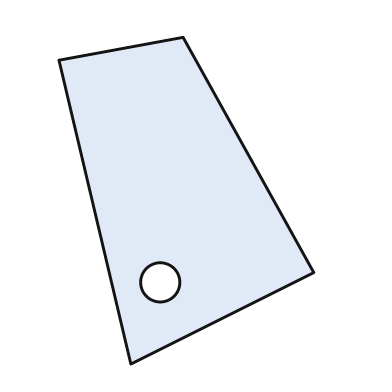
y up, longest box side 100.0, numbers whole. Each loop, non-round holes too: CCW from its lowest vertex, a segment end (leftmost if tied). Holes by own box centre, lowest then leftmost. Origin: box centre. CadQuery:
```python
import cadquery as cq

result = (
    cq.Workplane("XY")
    .moveTo(-17.0, -50.0)
    .lineTo(39.0, -22.0)
    .lineTo(-1.0, 50.0)
    .lineTo(-39.0, 43.0)
    .close()
    .moveTo(-8.0, -25.0)
    .circle(6.0)
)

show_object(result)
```